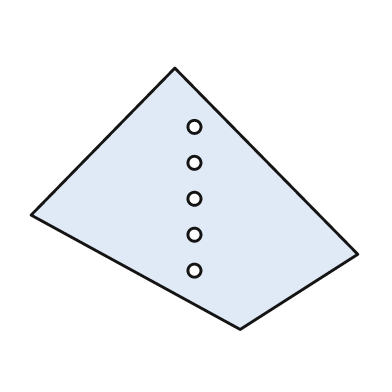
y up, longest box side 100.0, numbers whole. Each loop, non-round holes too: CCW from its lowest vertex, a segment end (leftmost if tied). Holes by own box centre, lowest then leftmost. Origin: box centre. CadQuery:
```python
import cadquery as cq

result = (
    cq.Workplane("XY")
    .moveTo(14.0, -40.0)
    .lineTo(50.0, -17.0)
    .lineTo(-6.0, 40.0)
    .lineTo(-50.0, -5.0)
    .close()
    .moveTo(0.0, -22.0)
    .circle(2.0)
    .moveTo(0.0, -11.0)
    .circle(2.0)
    .moveTo(0.0, 0.0)
    .circle(2.0)
    .moveTo(0.0, 11.0)
    .circle(2.0)
    .moveTo(0.0, 22.0)
    .circle(2.0)
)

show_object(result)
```